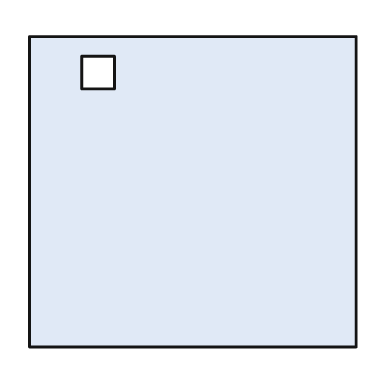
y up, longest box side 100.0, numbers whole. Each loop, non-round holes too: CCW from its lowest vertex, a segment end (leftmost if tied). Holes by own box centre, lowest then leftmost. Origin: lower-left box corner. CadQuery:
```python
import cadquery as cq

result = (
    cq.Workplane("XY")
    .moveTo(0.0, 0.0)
    .lineTo(100.0, 0.0)
    .lineTo(100.0, 95.0)
    .lineTo(0.0, 95.0)
    .close()
    .moveTo(16.0, 79.0)
    .lineTo(26.0, 79.0)
    .lineTo(26.0, 89.0)
    .lineTo(16.0, 89.0)
    .close()
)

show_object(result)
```